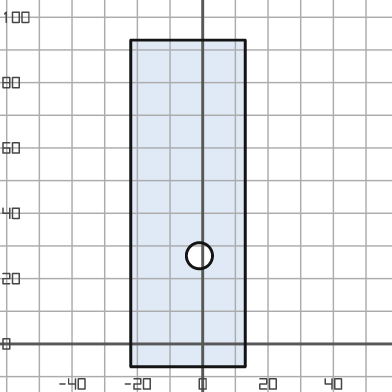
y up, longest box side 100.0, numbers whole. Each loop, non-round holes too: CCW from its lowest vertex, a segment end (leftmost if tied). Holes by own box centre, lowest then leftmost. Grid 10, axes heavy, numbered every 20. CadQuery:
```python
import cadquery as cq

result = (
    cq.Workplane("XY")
    .moveTo(-22.0, -7.0)
    .lineTo(13.0, -7.0)
    .lineTo(13.0, 93.0)
    .lineTo(-22.0, 93.0)
    .close()
    .moveTo(-1.0, 27.0)
    .circle(4.0)
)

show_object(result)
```